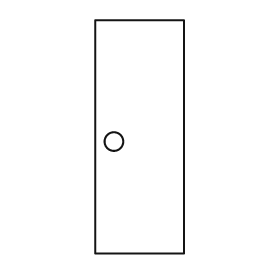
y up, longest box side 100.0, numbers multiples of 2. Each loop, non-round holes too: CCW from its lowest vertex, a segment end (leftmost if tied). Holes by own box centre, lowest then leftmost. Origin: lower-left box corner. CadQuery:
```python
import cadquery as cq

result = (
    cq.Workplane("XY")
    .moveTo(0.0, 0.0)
    .lineTo(38.0, 0.0)
    .lineTo(38.0, 100.0)
    .lineTo(0.0, 100.0)
    .close()
    .moveTo(8.0, 48.0)
    .circle(4.0)
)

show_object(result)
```